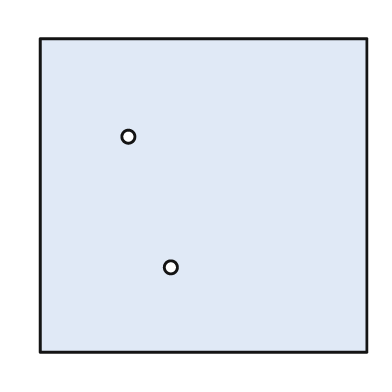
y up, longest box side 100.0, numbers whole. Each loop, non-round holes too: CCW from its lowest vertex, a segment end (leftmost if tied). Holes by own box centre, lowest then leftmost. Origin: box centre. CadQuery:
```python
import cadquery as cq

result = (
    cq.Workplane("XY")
    .moveTo(-50.0, -48.0)
    .lineTo(50.0, -48.0)
    .lineTo(50.0, 48.0)
    .lineTo(-50.0, 48.0)
    .close()
    .moveTo(-10.0, -22.0)
    .circle(2.0)
    .moveTo(-23.0, 18.0)
    .circle(2.0)
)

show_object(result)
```